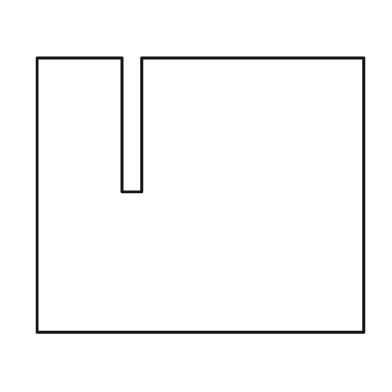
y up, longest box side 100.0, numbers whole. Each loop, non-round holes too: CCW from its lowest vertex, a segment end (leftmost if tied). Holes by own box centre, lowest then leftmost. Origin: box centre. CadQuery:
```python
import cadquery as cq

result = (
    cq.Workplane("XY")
    .moveTo(-50.0, -42.0)
    .lineTo(50.0, -42.0)
    .lineTo(50.0, 42.0)
    .lineTo(-18.0, 42.0)
    .lineTo(-18.0, 1.0)
    .lineTo(-24.0, 1.0)
    .lineTo(-24.0, 42.0)
    .lineTo(-50.0, 42.0)
    .close()
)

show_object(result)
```